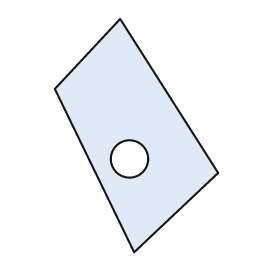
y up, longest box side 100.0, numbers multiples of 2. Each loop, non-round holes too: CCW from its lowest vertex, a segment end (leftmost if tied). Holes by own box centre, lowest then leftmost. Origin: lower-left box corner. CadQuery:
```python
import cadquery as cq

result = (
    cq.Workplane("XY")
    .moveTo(34.0, 0.0)
    .lineTo(70.0, 34.0)
    .lineTo(28.0, 100.0)
    .lineTo(0.0, 70.0)
    .close()
    .moveTo(32.0, 40.0)
    .circle(8.0)
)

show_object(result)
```